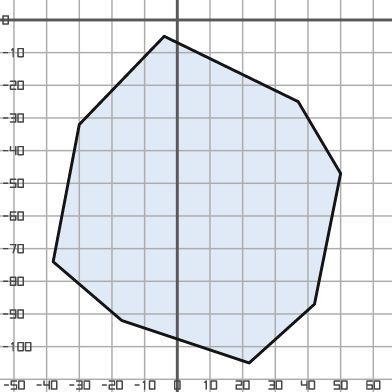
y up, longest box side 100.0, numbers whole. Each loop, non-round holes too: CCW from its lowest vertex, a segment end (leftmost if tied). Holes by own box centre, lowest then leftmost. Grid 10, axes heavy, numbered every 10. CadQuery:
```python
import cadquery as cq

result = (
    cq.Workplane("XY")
    .moveTo(22.0, -105.0)
    .lineTo(42.0, -87.0)
    .lineTo(50.0, -47.0)
    .lineTo(37.0, -25.0)
    .lineTo(-4.0, -5.0)
    .lineTo(-30.0, -32.0)
    .lineTo(-38.0, -74.0)
    .lineTo(-17.0, -92.0)
    .close()
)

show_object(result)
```